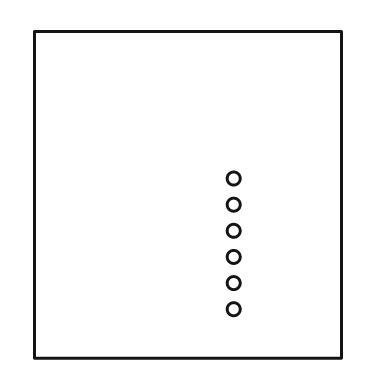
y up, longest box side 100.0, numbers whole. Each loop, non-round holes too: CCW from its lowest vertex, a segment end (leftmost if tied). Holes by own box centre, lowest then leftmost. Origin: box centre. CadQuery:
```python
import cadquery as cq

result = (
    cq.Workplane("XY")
    .moveTo(-47.0, -50.0)
    .lineTo(47.0, -50.0)
    .lineTo(47.0, 50.0)
    .lineTo(-47.0, 50.0)
    .close()
    .moveTo(14.0, -35.0)
    .circle(2.0)
    .moveTo(14.0, -27.0)
    .circle(2.0)
    .moveTo(14.0, -19.0)
    .circle(2.0)
    .moveTo(14.0, -11.0)
    .circle(2.0)
    .moveTo(14.0, -3.0)
    .circle(2.0)
    .moveTo(14.0, 5.0)
    .circle(2.0)
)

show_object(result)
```